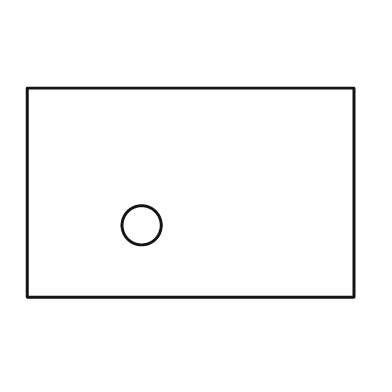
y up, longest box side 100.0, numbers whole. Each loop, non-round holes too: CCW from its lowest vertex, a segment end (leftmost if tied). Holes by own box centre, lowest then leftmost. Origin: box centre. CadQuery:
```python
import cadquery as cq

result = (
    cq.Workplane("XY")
    .moveTo(-50.0, -32.0)
    .lineTo(50.0, -32.0)
    .lineTo(50.0, 32.0)
    .lineTo(-50.0, 32.0)
    .close()
    .moveTo(-15.0, -10.0)
    .circle(6.0)
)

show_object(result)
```